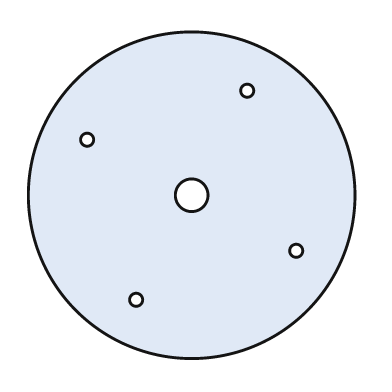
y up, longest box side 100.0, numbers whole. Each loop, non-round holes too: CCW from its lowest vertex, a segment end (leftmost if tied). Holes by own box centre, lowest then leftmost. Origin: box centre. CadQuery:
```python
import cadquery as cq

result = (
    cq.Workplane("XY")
    .moveTo(0.0, 0.0)
    .circle(50.0)
    .moveTo(-17.0, -32.0)
    .circle(2.0)
    .moveTo(32.0, -17.0)
    .circle(2.0)
    .moveTo(0.0, 0.0)
    .circle(5.0)
    .moveTo(-32.0, 17.0)
    .circle(2.0)
    .moveTo(17.0, 32.0)
    .circle(2.0)
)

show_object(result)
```